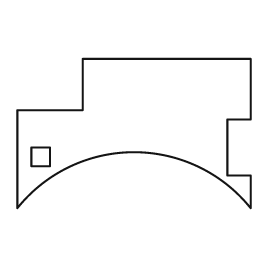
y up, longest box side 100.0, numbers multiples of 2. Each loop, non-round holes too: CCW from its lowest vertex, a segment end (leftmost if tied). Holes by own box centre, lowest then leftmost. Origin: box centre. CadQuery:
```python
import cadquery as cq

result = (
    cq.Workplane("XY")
    .moveTo(-50.0, -32.0)
    .threePointArc((0.0, -8.0), (50.0, -32.0))
    .lineTo(50.0, -18.0)
    .lineTo(40.0, -18.0)
    .lineTo(40.0, 6.0)
    .lineTo(50.0, 6.0)
    .lineTo(50.0, 32.0)
    .lineTo(-22.0, 32.0)
    .lineTo(-22.0, 10.0)
    .lineTo(-50.0, 10.0)
    .close()
    .moveTo(-44.0, -14.0)
    .lineTo(-36.0, -14.0)
    .lineTo(-36.0, -6.0)
    .lineTo(-44.0, -6.0)
    .close()
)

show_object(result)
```